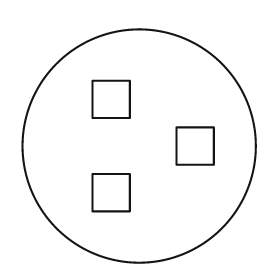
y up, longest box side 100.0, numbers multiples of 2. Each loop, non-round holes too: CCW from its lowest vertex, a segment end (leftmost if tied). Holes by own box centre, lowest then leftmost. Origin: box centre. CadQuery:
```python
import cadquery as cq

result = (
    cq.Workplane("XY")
    .moveTo(0.0, 0.0)
    .circle(50.0)
    .moveTo(-20.0, -28.0)
    .lineTo(-4.0, -28.0)
    .lineTo(-4.0, -12.0)
    .lineTo(-20.0, -12.0)
    .close()
    .moveTo(16.0, -8.0)
    .lineTo(32.0, -8.0)
    .lineTo(32.0, 8.0)
    .lineTo(16.0, 8.0)
    .close()
    .moveTo(-20.0, 12.0)
    .lineTo(-4.0, 12.0)
    .lineTo(-4.0, 28.0)
    .lineTo(-20.0, 28.0)
    .close()
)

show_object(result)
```